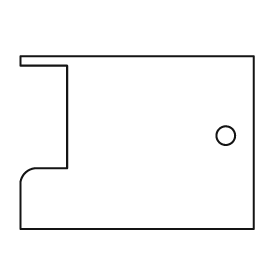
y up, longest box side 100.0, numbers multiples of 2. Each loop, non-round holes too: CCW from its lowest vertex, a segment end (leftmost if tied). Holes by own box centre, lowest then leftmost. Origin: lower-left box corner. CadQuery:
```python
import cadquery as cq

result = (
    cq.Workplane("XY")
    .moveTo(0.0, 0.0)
    .lineTo(100.0, 0.0)
    .lineTo(100.0, 74.0)
    .lineTo(0.0, 74.0)
    .lineTo(0.0, 70.0)
    .lineTo(20.0, 70.0)
    .lineTo(20.0, 26.0)
    .lineTo(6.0, 26.0)
    .threePointArc((2.0, 24.0), (0.0, 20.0))
    .close()
    .moveTo(88.0, 40.0)
    .circle(4.0)
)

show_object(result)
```